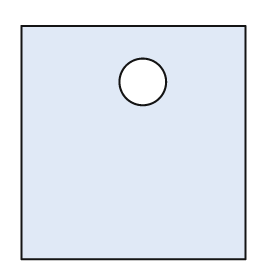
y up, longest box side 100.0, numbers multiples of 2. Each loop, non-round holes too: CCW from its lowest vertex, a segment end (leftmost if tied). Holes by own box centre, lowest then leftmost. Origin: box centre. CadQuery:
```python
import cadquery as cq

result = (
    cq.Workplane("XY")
    .moveTo(-48.0, -50.0)
    .lineTo(48.0, -50.0)
    .lineTo(48.0, 50.0)
    .lineTo(-48.0, 50.0)
    .close()
    .moveTo(4.0, 26.0)
    .circle(10.0)
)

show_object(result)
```